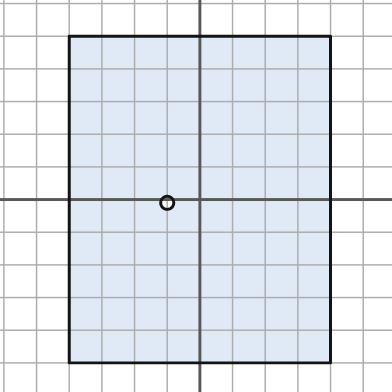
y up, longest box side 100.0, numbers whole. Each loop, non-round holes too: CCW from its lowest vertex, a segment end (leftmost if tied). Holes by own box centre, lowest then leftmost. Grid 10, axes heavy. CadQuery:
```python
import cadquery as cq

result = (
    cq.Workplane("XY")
    .moveTo(-40.0, -50.0)
    .lineTo(40.0, -50.0)
    .lineTo(40.0, 50.0)
    .lineTo(-40.0, 50.0)
    .close()
    .moveTo(-10.0, -1.0)
    .circle(2.0)
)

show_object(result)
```